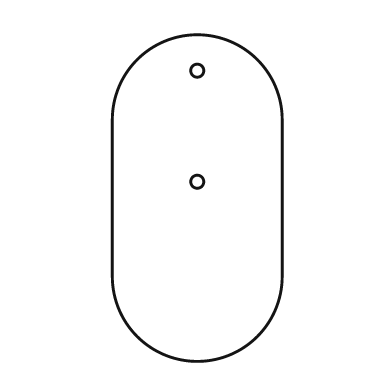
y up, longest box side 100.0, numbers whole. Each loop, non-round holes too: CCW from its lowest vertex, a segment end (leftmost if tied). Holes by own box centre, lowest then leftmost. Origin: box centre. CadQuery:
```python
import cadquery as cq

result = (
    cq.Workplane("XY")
    .moveTo(-26.0, -24.0)
    .threePointArc((0.0, -50.0), (26.0, -24.0))
    .lineTo(26.0, 24.0)
    .threePointArc((0.0, 50.0), (-26.0, 24.0))
    .close()
    .moveTo(0.0, 5.0)
    .circle(2.0)
    .moveTo(0.0, 39.0)
    .circle(2.0)
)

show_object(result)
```